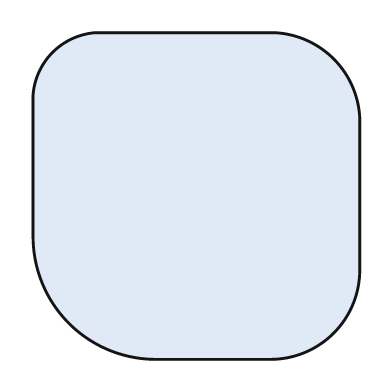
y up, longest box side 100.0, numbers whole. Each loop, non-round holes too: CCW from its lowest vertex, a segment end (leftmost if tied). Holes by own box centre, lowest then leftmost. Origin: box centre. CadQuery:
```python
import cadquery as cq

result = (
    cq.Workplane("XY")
    .moveTo(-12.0, -50.0)
    .lineTo(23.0, -50.0)
    .threePointArc((42.0, -42.0), (50.0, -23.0))
    .lineTo(50.0, 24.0)
    .threePointArc((42.0, 42.0), (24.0, 50.0))
    .lineTo(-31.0, 50.0)
    .threePointArc((-44.0, 44.0), (-50.0, 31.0))
    .lineTo(-50.0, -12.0)
    .threePointArc((-39.0, -39.0), (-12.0, -50.0))
    .close()
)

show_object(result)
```